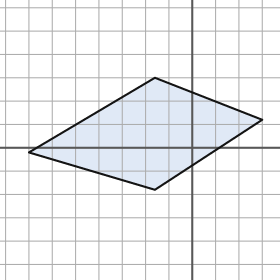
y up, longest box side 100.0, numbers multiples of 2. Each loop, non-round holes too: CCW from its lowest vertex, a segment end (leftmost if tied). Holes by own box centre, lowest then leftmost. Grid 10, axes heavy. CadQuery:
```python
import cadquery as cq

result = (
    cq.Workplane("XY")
    .moveTo(-16.0, -18.0)
    .lineTo(30.0, 12.0)
    .lineTo(-16.0, 30.0)
    .lineTo(-70.0, -2.0)
    .close()
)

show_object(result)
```